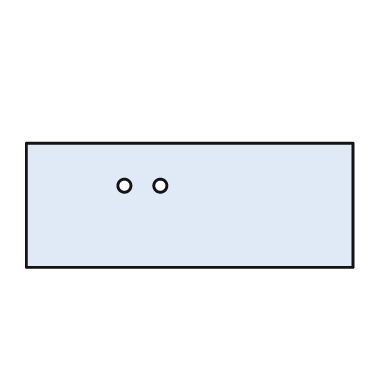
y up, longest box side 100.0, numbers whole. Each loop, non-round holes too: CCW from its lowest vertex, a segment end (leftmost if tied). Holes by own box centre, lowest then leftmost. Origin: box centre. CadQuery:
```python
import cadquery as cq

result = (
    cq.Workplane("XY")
    .moveTo(-50.0, -19.0)
    .lineTo(50.0, -19.0)
    .lineTo(50.0, 19.0)
    .lineTo(-50.0, 19.0)
    .close()
    .moveTo(-20.0, 6.0)
    .circle(2.0)
    .moveTo(-9.0, 6.0)
    .circle(2.0)
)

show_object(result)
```